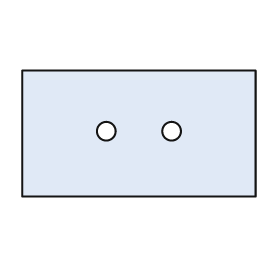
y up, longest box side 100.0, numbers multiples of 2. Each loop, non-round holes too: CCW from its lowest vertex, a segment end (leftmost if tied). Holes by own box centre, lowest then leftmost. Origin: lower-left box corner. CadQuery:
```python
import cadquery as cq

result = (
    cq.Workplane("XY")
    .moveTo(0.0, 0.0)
    .lineTo(100.0, 0.0)
    .lineTo(100.0, 54.0)
    .lineTo(0.0, 54.0)
    .close()
    .moveTo(36.0, 28.0)
    .circle(4.0)
    .moveTo(64.0, 28.0)
    .circle(4.0)
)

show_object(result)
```